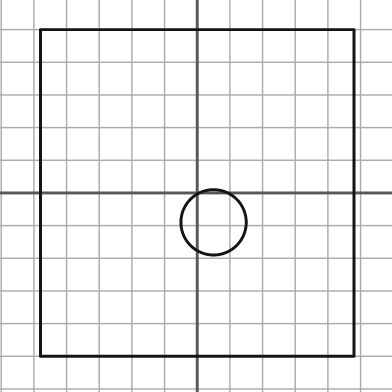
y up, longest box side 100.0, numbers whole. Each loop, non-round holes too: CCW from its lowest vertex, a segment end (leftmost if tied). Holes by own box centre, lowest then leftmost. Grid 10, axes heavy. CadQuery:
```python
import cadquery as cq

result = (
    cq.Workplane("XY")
    .moveTo(-48.0, -50.0)
    .lineTo(48.0, -50.0)
    .lineTo(48.0, 50.0)
    .lineTo(-48.0, 50.0)
    .close()
    .moveTo(5.0, -9.0)
    .circle(10.0)
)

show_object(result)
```